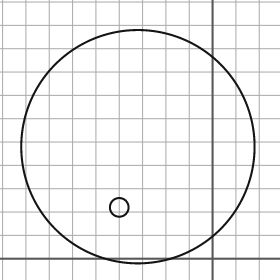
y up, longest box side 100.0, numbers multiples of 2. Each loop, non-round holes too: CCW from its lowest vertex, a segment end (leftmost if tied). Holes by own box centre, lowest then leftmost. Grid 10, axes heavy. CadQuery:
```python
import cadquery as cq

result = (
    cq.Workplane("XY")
    .moveTo(-32.0, 48.0)
    .circle(50.0)
    .moveTo(-40.0, 22.0)
    .circle(4.0)
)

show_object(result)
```